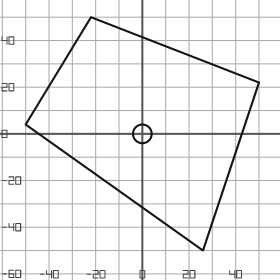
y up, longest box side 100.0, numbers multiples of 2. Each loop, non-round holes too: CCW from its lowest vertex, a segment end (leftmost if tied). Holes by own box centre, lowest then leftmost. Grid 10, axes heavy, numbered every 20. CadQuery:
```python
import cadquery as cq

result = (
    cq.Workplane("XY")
    .moveTo(26.0, -50.0)
    .lineTo(50.0, 22.0)
    .lineTo(-22.0, 50.0)
    .lineTo(-50.0, 4.0)
    .close()
    .moveTo(0.0, 0.0)
    .circle(4.0)
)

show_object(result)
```